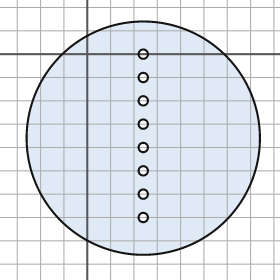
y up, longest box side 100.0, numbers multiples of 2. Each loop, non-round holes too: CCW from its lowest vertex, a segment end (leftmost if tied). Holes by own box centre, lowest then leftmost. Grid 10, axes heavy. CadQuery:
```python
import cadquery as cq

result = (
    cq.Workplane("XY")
    .moveTo(24.0, -36.0)
    .circle(50.0)
    .moveTo(24.0, -70.0)
    .circle(2.0)
    .moveTo(24.0, -60.0)
    .circle(2.0)
    .moveTo(24.0, -50.0)
    .circle(2.0)
    .moveTo(24.0, -40.0)
    .circle(2.0)
    .moveTo(24.0, -30.0)
    .circle(2.0)
    .moveTo(24.0, -20.0)
    .circle(2.0)
    .moveTo(24.0, -10.0)
    .circle(2.0)
    .moveTo(24.0, 0.0)
    .circle(2.0)
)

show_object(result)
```